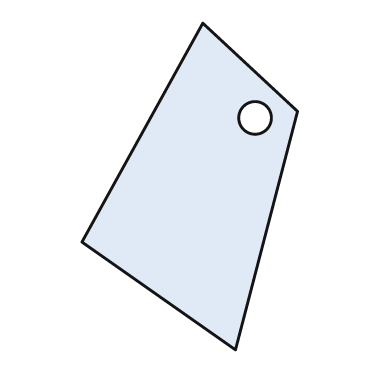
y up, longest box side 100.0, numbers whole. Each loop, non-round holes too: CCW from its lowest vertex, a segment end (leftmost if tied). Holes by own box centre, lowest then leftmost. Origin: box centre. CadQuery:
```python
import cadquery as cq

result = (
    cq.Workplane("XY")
    .moveTo(14.0, -50.0)
    .lineTo(33.0, 23.0)
    .lineTo(4.0, 50.0)
    .lineTo(-33.0, -17.0)
    .close()
    .moveTo(20.0, 21.0)
    .circle(5.0)
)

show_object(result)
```